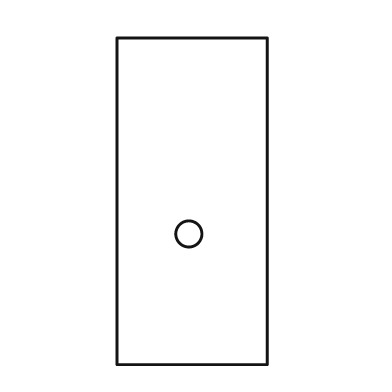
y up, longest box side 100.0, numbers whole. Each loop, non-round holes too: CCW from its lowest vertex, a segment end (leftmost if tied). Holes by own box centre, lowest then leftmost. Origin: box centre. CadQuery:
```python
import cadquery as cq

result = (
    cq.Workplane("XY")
    .moveTo(-23.0, -50.0)
    .lineTo(23.0, -50.0)
    .lineTo(23.0, 50.0)
    .lineTo(-23.0, 50.0)
    .close()
    .moveTo(-1.0, -10.0)
    .circle(4.0)
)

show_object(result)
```